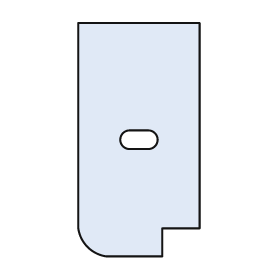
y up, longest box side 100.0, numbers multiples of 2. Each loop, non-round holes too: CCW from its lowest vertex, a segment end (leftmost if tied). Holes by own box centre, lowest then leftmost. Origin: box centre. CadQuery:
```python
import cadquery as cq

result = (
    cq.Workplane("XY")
    .moveTo(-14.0, -50.0)
    .lineTo(10.0, -50.0)
    .lineTo(10.0, -38.0)
    .lineTo(26.0, -38.0)
    .lineTo(26.0, 50.0)
    .lineTo(-26.0, 50.0)
    .lineTo(-26.0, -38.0)
    .threePointArc((-22.0, -46.0), (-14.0, -50.0))
    .close()
    .moveTo(-4.0, -4.0)
    .lineTo(4.0, -4.0)
    .threePointArc((8.0, 0.0), (4.0, 4.0))
    .lineTo(-4.0, 4.0)
    .threePointArc((-8.0, 0.0), (-4.0, -4.0))
    .close()
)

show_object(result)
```